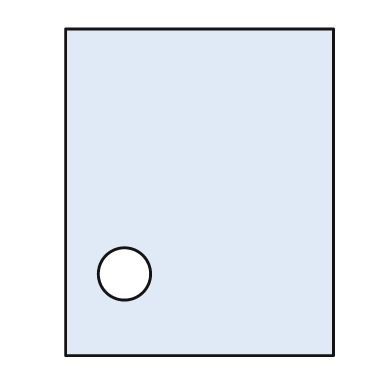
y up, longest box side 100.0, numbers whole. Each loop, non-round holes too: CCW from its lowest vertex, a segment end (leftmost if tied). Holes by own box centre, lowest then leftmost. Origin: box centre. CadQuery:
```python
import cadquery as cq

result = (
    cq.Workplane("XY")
    .moveTo(-41.0, -50.0)
    .lineTo(41.0, -50.0)
    .lineTo(41.0, 50.0)
    .lineTo(-41.0, 50.0)
    .close()
    .moveTo(-23.0, -25.0)
    .circle(8.0)
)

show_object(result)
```